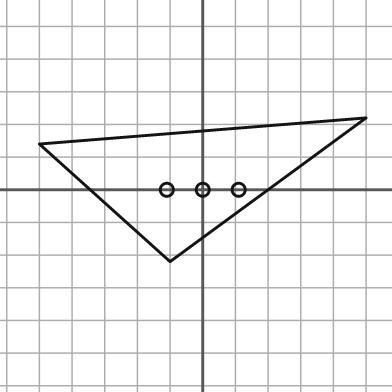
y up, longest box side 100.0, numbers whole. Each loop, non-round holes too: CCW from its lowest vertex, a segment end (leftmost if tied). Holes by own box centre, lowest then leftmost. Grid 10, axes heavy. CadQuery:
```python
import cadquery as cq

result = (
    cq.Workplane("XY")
    .moveTo(-10.0, -22.0)
    .lineTo(50.0, 22.0)
    .lineTo(-50.0, 14.0)
    .close()
    .moveTo(-11.0, 0.0)
    .circle(2.0)
    .moveTo(0.0, 0.0)
    .circle(2.0)
    .moveTo(11.0, 0.0)
    .circle(2.0)
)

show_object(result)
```